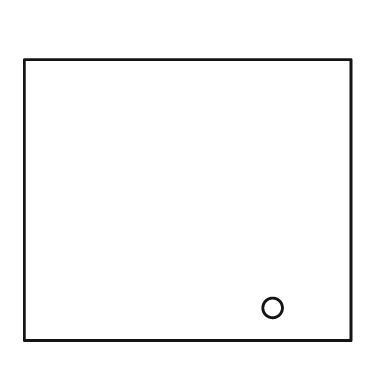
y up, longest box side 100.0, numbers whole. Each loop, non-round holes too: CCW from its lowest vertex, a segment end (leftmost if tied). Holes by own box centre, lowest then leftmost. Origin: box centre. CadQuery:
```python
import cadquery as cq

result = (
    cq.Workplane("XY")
    .moveTo(-50.0, -43.0)
    .lineTo(50.0, -43.0)
    .lineTo(50.0, 43.0)
    .lineTo(-50.0, 43.0)
    .close()
    .moveTo(26.0, -33.0)
    .circle(3.0)
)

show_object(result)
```